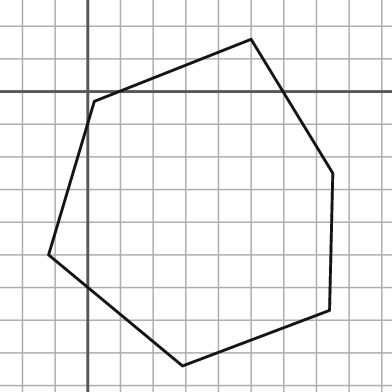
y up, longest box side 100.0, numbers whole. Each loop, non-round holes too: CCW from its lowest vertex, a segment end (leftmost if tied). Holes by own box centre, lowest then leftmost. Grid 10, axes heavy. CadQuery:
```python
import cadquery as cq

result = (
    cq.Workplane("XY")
    .moveTo(29.0, -84.0)
    .lineTo(74.0, -67.0)
    .lineTo(75.0, -25.0)
    .lineTo(50.0, 16.0)
    .lineTo(2.0, -3.0)
    .lineTo(-12.0, -50.0)
    .close()
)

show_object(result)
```